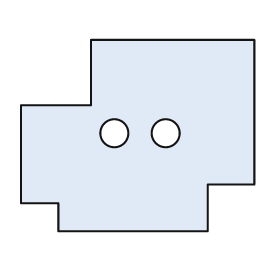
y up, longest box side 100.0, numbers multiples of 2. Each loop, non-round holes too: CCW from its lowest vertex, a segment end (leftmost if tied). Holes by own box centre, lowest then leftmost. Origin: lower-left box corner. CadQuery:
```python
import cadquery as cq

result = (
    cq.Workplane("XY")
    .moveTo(16.0, 0.0)
    .lineTo(80.0, 0.0)
    .lineTo(80.0, 20.0)
    .lineTo(100.0, 20.0)
    .lineTo(100.0, 82.0)
    .lineTo(30.0, 82.0)
    .lineTo(30.0, 54.0)
    .lineTo(0.0, 54.0)
    .lineTo(0.0, 12.0)
    .lineTo(16.0, 12.0)
    .close()
    .moveTo(40.0, 42.0)
    .circle(6.0)
    .moveTo(62.0, 42.0)
    .circle(6.0)
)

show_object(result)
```